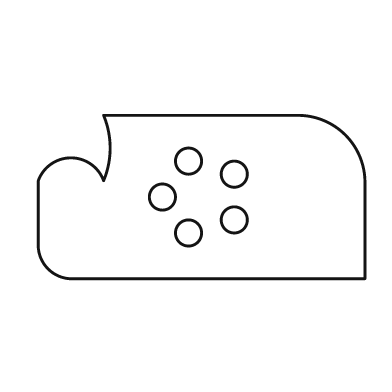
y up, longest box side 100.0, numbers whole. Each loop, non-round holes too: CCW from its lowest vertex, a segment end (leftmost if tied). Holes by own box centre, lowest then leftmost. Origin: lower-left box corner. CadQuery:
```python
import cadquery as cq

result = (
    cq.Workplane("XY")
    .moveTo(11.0, 0.0)
    .lineTo(100.0, 0.0)
    .lineTo(100.0, 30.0)
    .threePointArc((94.0, 44.0), (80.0, 50.0))
    .lineTo(20.0, 50.0)
    .threePointArc((22.0, 40.0), (20.0, 30.0))
    .threePointArc((10.0, 37.0), (0.0, 30.0))
    .lineTo(0.0, 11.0)
    .threePointArc((3.0, 3.0), (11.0, 0.0))
    .close()
    .moveTo(46.0, 14.0)
    .circle(4.0)
    .moveTo(60.0, 18.0)
    .circle(4.0)
    .moveTo(38.0, 25.0)
    .circle(4.0)
    .moveTo(60.0, 32.0)
    .circle(4.0)
    .moveTo(46.0, 36.0)
    .circle(4.0)
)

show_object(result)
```